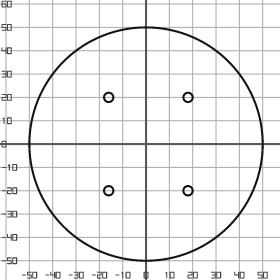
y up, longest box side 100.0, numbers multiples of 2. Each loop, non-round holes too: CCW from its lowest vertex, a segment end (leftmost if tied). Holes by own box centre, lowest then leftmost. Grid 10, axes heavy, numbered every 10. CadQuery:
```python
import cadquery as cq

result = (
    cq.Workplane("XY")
    .moveTo(0.0, 0.0)
    .circle(50.0)
    .moveTo(-16.0, -20.0)
    .circle(2.0)
    .moveTo(18.0, -20.0)
    .circle(2.0)
    .moveTo(-16.0, 20.0)
    .circle(2.0)
    .moveTo(18.0, 20.0)
    .circle(2.0)
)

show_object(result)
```